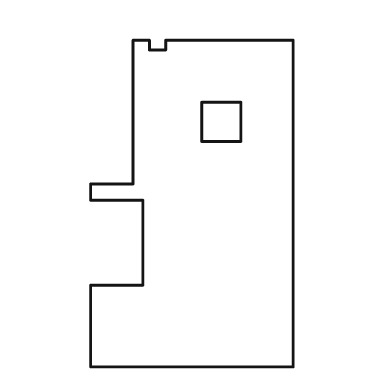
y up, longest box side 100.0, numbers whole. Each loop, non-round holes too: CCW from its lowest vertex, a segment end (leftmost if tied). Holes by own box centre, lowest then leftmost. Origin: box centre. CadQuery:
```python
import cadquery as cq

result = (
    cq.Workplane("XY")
    .moveTo(-31.0, -50.0)
    .lineTo(31.0, -50.0)
    .lineTo(31.0, 50.0)
    .lineTo(-8.0, 50.0)
    .lineTo(-8.0, 47.0)
    .lineTo(-13.0, 47.0)
    .lineTo(-13.0, 50.0)
    .lineTo(-18.0, 50.0)
    .lineTo(-18.0, 6.0)
    .lineTo(-31.0, 6.0)
    .lineTo(-31.0, 1.0)
    .lineTo(-15.0, 1.0)
    .lineTo(-15.0, -25.0)
    .lineTo(-31.0, -25.0)
    .close()
    .moveTo(3.0, 19.0)
    .lineTo(15.0, 19.0)
    .lineTo(15.0, 31.0)
    .lineTo(3.0, 31.0)
    .close()
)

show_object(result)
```